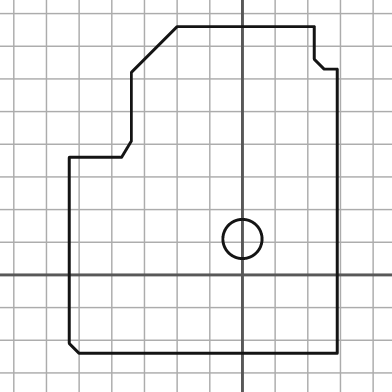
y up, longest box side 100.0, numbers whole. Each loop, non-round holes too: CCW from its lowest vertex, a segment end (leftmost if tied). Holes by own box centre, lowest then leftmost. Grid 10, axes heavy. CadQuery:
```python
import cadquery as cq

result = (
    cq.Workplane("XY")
    .moveTo(-50.0, -24.0)
    .lineTo(29.0, -24.0)
    .lineTo(29.0, 63.0)
    .lineTo(25.0, 63.0)
    .lineTo(22.0, 66.0)
    .lineTo(22.0, 76.0)
    .lineTo(-20.0, 76.0)
    .lineTo(-34.0, 62.0)
    .lineTo(-34.0, 41.0)
    .lineTo(-37.0, 36.0)
    .lineTo(-53.0, 36.0)
    .lineTo(-53.0, -21.0)
    .close()
    .moveTo(0.0, 11.0)
    .circle(6.0)
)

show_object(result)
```